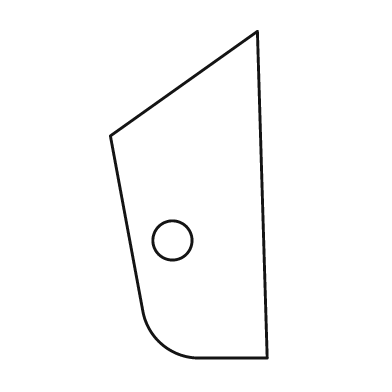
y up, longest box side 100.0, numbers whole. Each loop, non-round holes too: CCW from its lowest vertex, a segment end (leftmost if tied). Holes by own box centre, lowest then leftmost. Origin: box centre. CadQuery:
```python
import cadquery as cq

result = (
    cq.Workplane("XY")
    .moveTo(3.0, -50.0)
    .lineTo(24.0, -50.0)
    .lineTo(21.0, 50.0)
    .lineTo(-24.0, 18.0)
    .lineTo(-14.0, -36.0)
    .threePointArc((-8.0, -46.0), (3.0, -50.0))
    .close()
    .moveTo(-5.0, -14.0)
    .circle(6.0)
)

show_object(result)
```